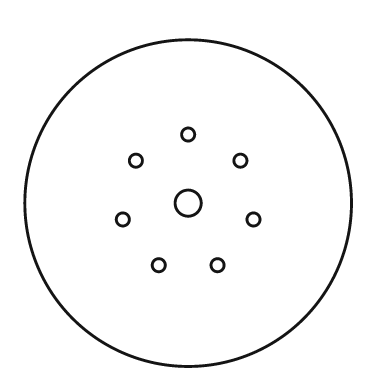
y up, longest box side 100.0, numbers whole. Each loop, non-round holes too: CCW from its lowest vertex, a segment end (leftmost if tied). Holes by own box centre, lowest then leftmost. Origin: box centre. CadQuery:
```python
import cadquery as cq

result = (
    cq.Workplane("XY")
    .moveTo(0.0, 0.0)
    .circle(50.0)
    .moveTo(-9.0, -19.0)
    .circle(2.0)
    .moveTo(9.0, -19.0)
    .circle(2.0)
    .moveTo(-20.0, -5.0)
    .circle(2.0)
    .moveTo(20.0, -5.0)
    .circle(2.0)
    .moveTo(0.0, 0.0)
    .circle(4.0)
    .moveTo(-16.0, 13.0)
    .circle(2.0)
    .moveTo(16.0, 13.0)
    .circle(2.0)
    .moveTo(0.0, 21.0)
    .circle(2.0)
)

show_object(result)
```